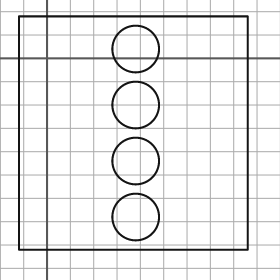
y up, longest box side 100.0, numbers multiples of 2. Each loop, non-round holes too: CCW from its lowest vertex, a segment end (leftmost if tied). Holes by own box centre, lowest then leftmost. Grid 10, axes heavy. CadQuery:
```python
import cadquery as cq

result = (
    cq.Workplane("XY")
    .moveTo(-12.0, -82.0)
    .lineTo(86.0, -82.0)
    .lineTo(86.0, 18.0)
    .lineTo(-12.0, 18.0)
    .close()
    .moveTo(38.0, -68.0)
    .circle(10.0)
    .moveTo(38.0, -44.0)
    .circle(10.0)
    .moveTo(38.0, -20.0)
    .circle(10.0)
    .moveTo(38.0, 4.0)
    .circle(10.0)
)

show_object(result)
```